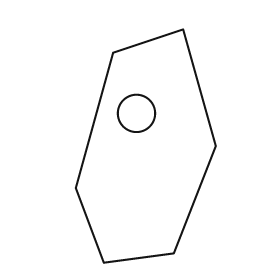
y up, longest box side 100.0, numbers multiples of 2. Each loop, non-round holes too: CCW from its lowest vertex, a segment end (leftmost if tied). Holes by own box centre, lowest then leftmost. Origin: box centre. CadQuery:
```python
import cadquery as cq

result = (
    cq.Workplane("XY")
    .moveTo(-18.0, -50.0)
    .lineTo(12.0, -46.0)
    .lineTo(30.0, 0.0)
    .lineTo(16.0, 50.0)
    .lineTo(-14.0, 40.0)
    .lineTo(-30.0, -18.0)
    .close()
    .moveTo(-4.0, 14.0)
    .circle(8.0)
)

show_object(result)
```